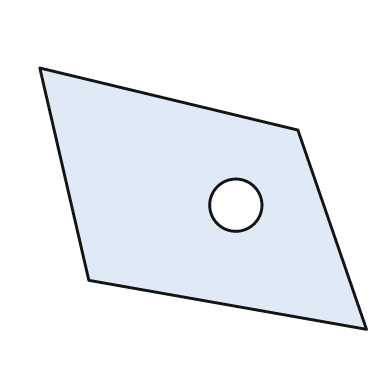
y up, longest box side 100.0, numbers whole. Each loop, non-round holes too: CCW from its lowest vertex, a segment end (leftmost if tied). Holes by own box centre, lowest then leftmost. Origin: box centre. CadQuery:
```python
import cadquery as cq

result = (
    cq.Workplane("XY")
    .moveTo(50.0, -40.0)
    .lineTo(29.0, 21.0)
    .lineTo(-50.0, 40.0)
    .lineTo(-35.0, -25.0)
    .close()
    .moveTo(10.0, -2.0)
    .circle(8.0)
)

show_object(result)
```